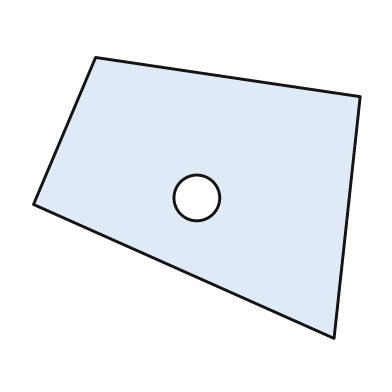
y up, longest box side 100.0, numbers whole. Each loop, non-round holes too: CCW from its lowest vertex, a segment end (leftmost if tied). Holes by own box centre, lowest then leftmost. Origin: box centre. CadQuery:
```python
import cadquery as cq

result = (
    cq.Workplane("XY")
    .moveTo(42.0, -43.0)
    .lineTo(50.0, 31.0)
    .lineTo(-31.0, 43.0)
    .lineTo(-50.0, -2.0)
    .close()
    .moveTo(0.0, 0.0)
    .circle(7.0)
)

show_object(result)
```